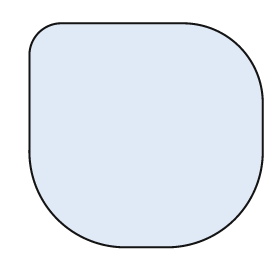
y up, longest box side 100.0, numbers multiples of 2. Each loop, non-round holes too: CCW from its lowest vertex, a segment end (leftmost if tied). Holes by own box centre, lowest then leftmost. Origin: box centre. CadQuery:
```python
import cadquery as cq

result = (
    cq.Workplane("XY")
    .moveTo(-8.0, -48.0)
    .lineTo(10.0, -48.0)
    .threePointArc((38.0, -36.0), (50.0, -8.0))
    .lineTo(50.0, 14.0)
    .threePointArc((40.0, 38.0), (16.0, 48.0))
    .lineTo(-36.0, 48.0)
    .threePointArc((-46.0, 44.0), (-50.0, 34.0))
    .lineTo(-50.0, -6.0)
    .threePointArc((-38.0, -36.0), (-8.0, -48.0))
    .close()
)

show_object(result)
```